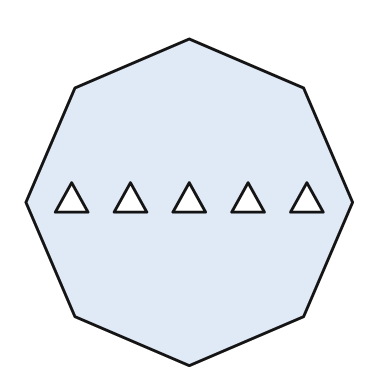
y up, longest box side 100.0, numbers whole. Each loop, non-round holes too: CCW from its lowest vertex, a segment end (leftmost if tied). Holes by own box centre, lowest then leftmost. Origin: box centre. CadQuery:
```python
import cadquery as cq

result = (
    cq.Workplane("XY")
    .moveTo(0.0, -50.0)
    .lineTo(35.0, -35.0)
    .lineTo(50.0, 0.0)
    .lineTo(35.0, 35.0)
    .lineTo(0.0, 50.0)
    .lineTo(-35.0, 35.0)
    .lineTo(-50.0, 0.0)
    .lineTo(-35.0, -35.0)
    .close()
    .moveTo(-41.0, -3.0)
    .lineTo(-31.0, -3.0)
    .lineTo(-36.0, 6.0)
    .close()
    .moveTo(-23.0, -3.0)
    .lineTo(-13.0, -3.0)
    .lineTo(-18.0, 6.0)
    .close()
    .moveTo(-5.0, -3.0)
    .lineTo(5.0, -3.0)
    .lineTo(0.0, 6.0)
    .close()
    .moveTo(13.0, -3.0)
    .lineTo(23.0, -3.0)
    .lineTo(18.0, 6.0)
    .close()
    .moveTo(31.0, -3.0)
    .lineTo(41.0, -3.0)
    .lineTo(36.0, 6.0)
    .close()
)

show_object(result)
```